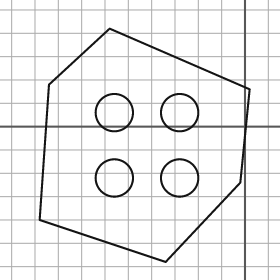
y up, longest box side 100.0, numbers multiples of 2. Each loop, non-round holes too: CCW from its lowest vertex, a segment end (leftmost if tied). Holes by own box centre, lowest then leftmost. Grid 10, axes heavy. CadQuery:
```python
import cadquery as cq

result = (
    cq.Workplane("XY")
    .moveTo(-34.0, -58.0)
    .lineTo(-2.0, -24.0)
    .lineTo(2.0, 16.0)
    .lineTo(-58.0, 42.0)
    .lineTo(-84.0, 18.0)
    .lineTo(-88.0, -40.0)
    .close()
    .moveTo(-56.0, -22.0)
    .circle(8.0)
    .moveTo(-28.0, -22.0)
    .circle(8.0)
    .moveTo(-56.0, 6.0)
    .circle(8.0)
    .moveTo(-28.0, 6.0)
    .circle(8.0)
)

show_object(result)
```